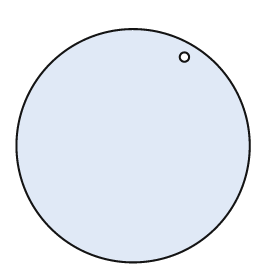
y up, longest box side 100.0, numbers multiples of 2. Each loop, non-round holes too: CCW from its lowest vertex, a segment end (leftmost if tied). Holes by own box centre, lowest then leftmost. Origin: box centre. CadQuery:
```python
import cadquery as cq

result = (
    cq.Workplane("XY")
    .moveTo(0.0, 0.0)
    .circle(50.0)
    .moveTo(22.0, 38.0)
    .circle(2.0)
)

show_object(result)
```